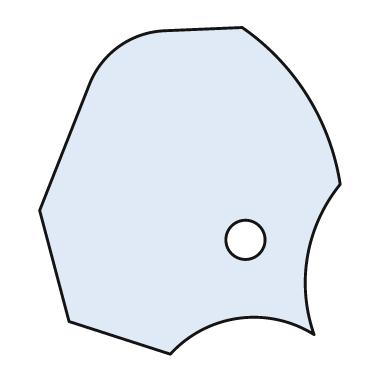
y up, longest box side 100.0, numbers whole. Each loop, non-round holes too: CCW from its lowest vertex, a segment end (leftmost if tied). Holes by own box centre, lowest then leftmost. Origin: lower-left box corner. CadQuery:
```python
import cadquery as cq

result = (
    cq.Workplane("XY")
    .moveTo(40.0, 0.0)
    .threePointArc((61.0, 11.0), (84.0, 6.0))
    .threePointArc((82.0, 30.0), (92.0, 52.0))
    .threePointArc((82.0, 79.0), (62.0, 100.0))
    .lineTo(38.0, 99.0)
    .threePointArc((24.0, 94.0), (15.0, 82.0))
    .lineTo(0.0, 44.0)
    .lineTo(9.0, 10.0)
    .close()
    .moveTo(63.0, 35.0)
    .circle(6.0)
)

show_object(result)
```